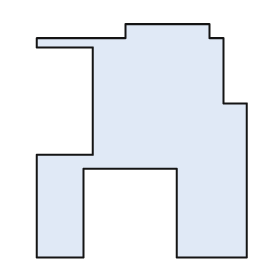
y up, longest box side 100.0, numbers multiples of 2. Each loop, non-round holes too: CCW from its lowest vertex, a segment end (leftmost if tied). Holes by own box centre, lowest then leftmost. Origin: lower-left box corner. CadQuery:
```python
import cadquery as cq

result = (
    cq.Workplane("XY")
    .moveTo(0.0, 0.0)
    .lineTo(20.0, 0.0)
    .lineTo(20.0, 38.0)
    .lineTo(60.0, 38.0)
    .lineTo(60.0, 0.0)
    .lineTo(90.0, 0.0)
    .lineTo(90.0, 66.0)
    .lineTo(80.0, 66.0)
    .lineTo(80.0, 94.0)
    .lineTo(74.0, 94.0)
    .lineTo(74.0, 100.0)
    .lineTo(38.0, 100.0)
    .lineTo(38.0, 94.0)
    .lineTo(0.0, 94.0)
    .lineTo(0.0, 90.0)
    .lineTo(24.0, 90.0)
    .lineTo(24.0, 44.0)
    .lineTo(0.0, 44.0)
    .close()
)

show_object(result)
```